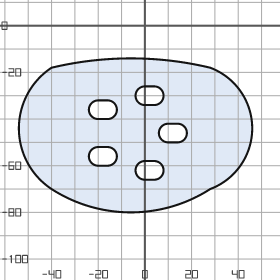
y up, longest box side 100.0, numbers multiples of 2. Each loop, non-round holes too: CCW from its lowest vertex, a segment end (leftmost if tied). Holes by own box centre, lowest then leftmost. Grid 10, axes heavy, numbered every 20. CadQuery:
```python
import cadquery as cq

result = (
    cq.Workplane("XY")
    .moveTo(-40.0, -70.0)
    .threePointArc((-6.0, -80.0), (28.0, -70.0))
    .threePointArc((46.0, -44.0), (28.0, -18.0))
    .threePointArc((-6.0, -14.0), (-40.0, -18.0))
    .threePointArc((-54.0, -44.0), (-40.0, -70.0))
    .close()
    .moveTo(0.0, -66.0)
    .lineTo(4.0, -66.0)
    .threePointArc((8.0, -62.0), (4.0, -58.0))
    .lineTo(0.0, -58.0)
    .threePointArc((-4.0, -62.0), (0.0, -66.0))
    .close()
    .moveTo(-20.0, -60.0)
    .lineTo(-16.0, -60.0)
    .threePointArc((-12.0, -56.0), (-16.0, -52.0))
    .lineTo(-20.0, -52.0)
    .threePointArc((-24.0, -56.0), (-20.0, -60.0))
    .close()
    .moveTo(10.0, -50.0)
    .lineTo(14.0, -50.0)
    .threePointArc((18.0, -46.0), (14.0, -42.0))
    .lineTo(10.0, -42.0)
    .threePointArc((6.0, -46.0), (10.0, -50.0))
    .close()
    .moveTo(-20.0, -40.0)
    .lineTo(-16.0, -40.0)
    .threePointArc((-12.0, -36.0), (-16.0, -32.0))
    .lineTo(-20.0, -32.0)
    .threePointArc((-24.0, -36.0), (-20.0, -40.0))
    .close()
    .moveTo(0.0, -34.0)
    .lineTo(4.0, -34.0)
    .threePointArc((8.0, -30.0), (4.0, -26.0))
    .lineTo(0.0, -26.0)
    .threePointArc((-4.0, -30.0), (0.0, -34.0))
    .close()
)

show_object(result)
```